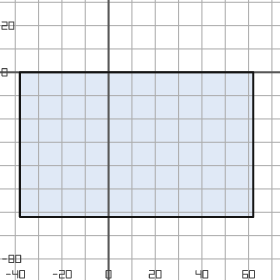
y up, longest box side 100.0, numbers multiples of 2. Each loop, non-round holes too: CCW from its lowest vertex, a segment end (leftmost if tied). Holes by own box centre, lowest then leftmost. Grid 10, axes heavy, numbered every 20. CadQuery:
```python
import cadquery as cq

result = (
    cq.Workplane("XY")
    .moveTo(-38.0, -62.0)
    .lineTo(62.0, -62.0)
    .lineTo(62.0, 0.0)
    .lineTo(-38.0, 0.0)
    .close()
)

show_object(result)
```